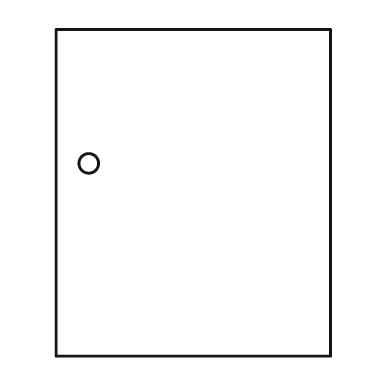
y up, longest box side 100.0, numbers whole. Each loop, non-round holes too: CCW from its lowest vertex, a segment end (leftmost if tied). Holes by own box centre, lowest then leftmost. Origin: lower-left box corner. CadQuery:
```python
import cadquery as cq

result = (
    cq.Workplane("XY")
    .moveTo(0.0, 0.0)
    .lineTo(84.0, 0.0)
    .lineTo(84.0, 100.0)
    .lineTo(0.0, 100.0)
    .close()
    .moveTo(10.0, 59.0)
    .circle(3.0)
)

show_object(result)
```